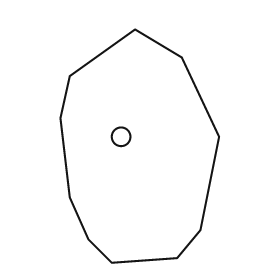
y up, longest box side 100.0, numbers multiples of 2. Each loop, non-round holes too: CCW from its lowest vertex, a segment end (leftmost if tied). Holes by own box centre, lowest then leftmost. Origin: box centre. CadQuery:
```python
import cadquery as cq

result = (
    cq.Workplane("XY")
    .moveTo(-12.0, -50.0)
    .lineTo(16.0, -48.0)
    .lineTo(26.0, -36.0)
    .lineTo(34.0, 4.0)
    .lineTo(18.0, 38.0)
    .lineTo(-2.0, 50.0)
    .lineTo(-30.0, 30.0)
    .lineTo(-34.0, 12.0)
    .lineTo(-30.0, -22.0)
    .lineTo(-22.0, -40.0)
    .close()
    .moveTo(-8.0, 4.0)
    .circle(4.0)
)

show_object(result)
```